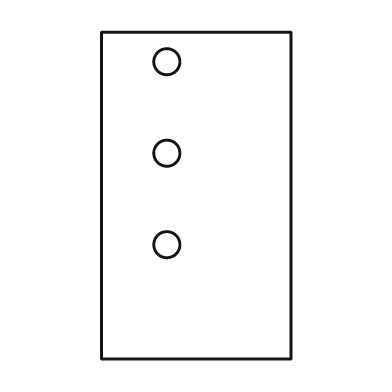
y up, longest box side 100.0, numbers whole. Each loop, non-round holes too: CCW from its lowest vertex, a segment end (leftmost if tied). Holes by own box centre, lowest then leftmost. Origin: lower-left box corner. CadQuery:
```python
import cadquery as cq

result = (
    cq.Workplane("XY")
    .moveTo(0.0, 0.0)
    .lineTo(58.0, 0.0)
    .lineTo(58.0, 100.0)
    .lineTo(0.0, 100.0)
    .close()
    .moveTo(20.0, 35.0)
    .circle(4.0)
    .moveTo(20.0, 63.0)
    .circle(4.0)
    .moveTo(20.0, 91.0)
    .circle(4.0)
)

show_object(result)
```